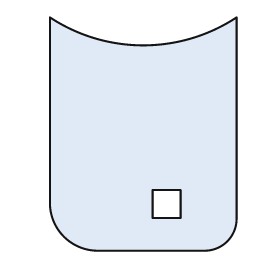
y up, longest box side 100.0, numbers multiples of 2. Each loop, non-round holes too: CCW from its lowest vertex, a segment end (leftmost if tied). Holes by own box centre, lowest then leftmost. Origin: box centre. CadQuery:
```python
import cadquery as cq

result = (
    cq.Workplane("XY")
    .moveTo(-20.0, -50.0)
    .lineTo(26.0, -50.0)
    .threePointArc((36.0, -46.0), (40.0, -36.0))
    .lineTo(40.0, 50.0)
    .threePointArc((0.0, 38.0), (-40.0, 50.0))
    .lineTo(-40.0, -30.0)
    .threePointArc((-34.0, -44.0), (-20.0, -50.0))
    .close()
    .moveTo(4.0, -36.0)
    .lineTo(16.0, -36.0)
    .lineTo(16.0, -24.0)
    .lineTo(4.0, -24.0)
    .close()
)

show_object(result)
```